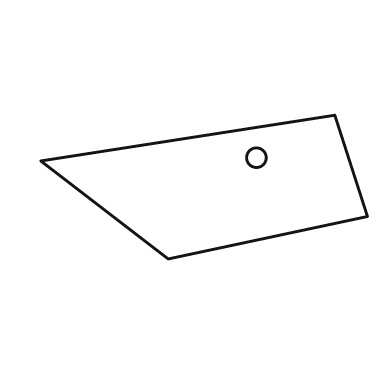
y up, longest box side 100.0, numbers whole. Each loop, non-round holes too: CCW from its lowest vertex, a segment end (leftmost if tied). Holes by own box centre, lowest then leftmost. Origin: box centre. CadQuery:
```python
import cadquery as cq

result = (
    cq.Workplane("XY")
    .moveTo(-11.0, -22.0)
    .lineTo(50.0, -9.0)
    .lineTo(40.0, 22.0)
    .lineTo(-50.0, 8.0)
    .close()
    .moveTo(16.0, 9.0)
    .circle(3.0)
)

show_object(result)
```